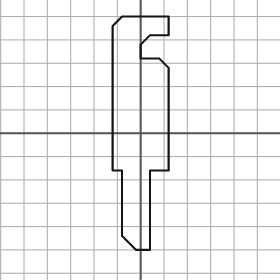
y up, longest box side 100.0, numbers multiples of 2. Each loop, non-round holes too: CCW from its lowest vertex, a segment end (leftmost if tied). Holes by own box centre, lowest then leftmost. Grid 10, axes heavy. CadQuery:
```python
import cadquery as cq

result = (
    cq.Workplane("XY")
    .moveTo(-2.0, -50.0)
    .lineTo(4.0, -50.0)
    .lineTo(4.0, -16.0)
    .lineTo(12.0, -16.0)
    .lineTo(12.0, 28.0)
    .lineTo(8.0, 32.0)
    .lineTo(0.0, 32.0)
    .lineTo(0.0, 38.0)
    .lineTo(4.0, 42.0)
    .lineTo(12.0, 42.0)
    .lineTo(12.0, 50.0)
    .lineTo(-8.0, 50.0)
    .lineTo(-12.0, 46.0)
    .lineTo(-12.0, -16.0)
    .lineTo(-8.0, -16.0)
    .lineTo(-8.0, -44.0)
    .close()
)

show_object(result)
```